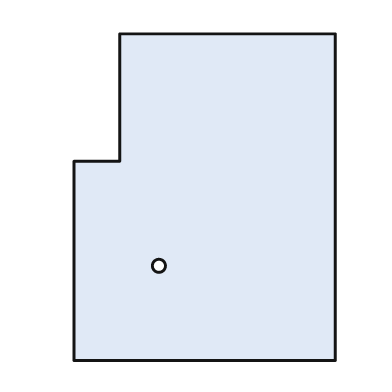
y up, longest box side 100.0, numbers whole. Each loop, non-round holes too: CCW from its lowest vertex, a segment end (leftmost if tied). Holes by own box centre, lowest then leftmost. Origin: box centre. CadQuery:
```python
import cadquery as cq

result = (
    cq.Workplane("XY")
    .moveTo(-40.0, -50.0)
    .lineTo(40.0, -50.0)
    .lineTo(40.0, 50.0)
    .lineTo(-26.0, 50.0)
    .lineTo(-26.0, 11.0)
    .lineTo(-40.0, 11.0)
    .close()
    .moveTo(-14.0, -21.0)
    .circle(2.0)
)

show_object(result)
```